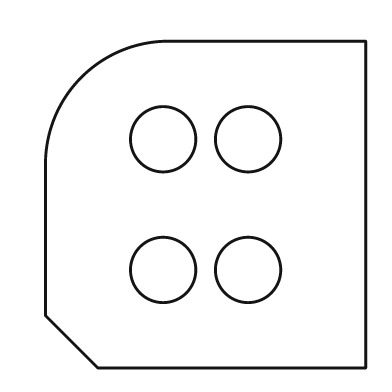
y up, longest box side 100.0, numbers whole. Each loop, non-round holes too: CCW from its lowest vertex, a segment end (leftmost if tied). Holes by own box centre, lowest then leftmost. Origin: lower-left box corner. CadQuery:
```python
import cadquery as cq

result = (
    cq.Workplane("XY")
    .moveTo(16.0, 0.0)
    .lineTo(98.0, 0.0)
    .lineTo(98.0, 100.0)
    .lineTo(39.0, 100.0)
    .threePointArc((11.0, 89.0), (0.0, 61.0))
    .lineTo(0.0, 16.0)
    .close()
    .moveTo(36.0, 30.0)
    .circle(10.0)
    .moveTo(62.0, 30.0)
    .circle(10.0)
    .moveTo(36.0, 70.0)
    .circle(10.0)
    .moveTo(62.0, 70.0)
    .circle(10.0)
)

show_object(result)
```